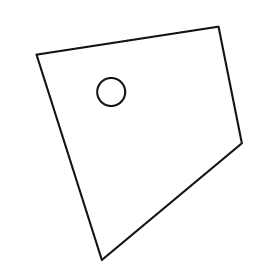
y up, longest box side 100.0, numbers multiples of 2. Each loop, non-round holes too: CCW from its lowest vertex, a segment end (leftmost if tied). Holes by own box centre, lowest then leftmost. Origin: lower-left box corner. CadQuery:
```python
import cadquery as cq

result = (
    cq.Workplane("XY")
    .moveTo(28.0, 0.0)
    .lineTo(88.0, 50.0)
    .lineTo(78.0, 100.0)
    .lineTo(0.0, 88.0)
    .close()
    .moveTo(32.0, 72.0)
    .circle(6.0)
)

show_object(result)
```